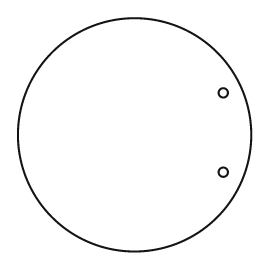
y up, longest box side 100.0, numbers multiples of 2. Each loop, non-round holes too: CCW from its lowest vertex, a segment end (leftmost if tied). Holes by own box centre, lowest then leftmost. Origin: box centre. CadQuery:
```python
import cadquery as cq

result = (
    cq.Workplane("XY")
    .moveTo(0.0, 0.0)
    .circle(50.0)
    .moveTo(38.0, -16.0)
    .circle(2.0)
    .moveTo(38.0, 18.0)
    .circle(2.0)
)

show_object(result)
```